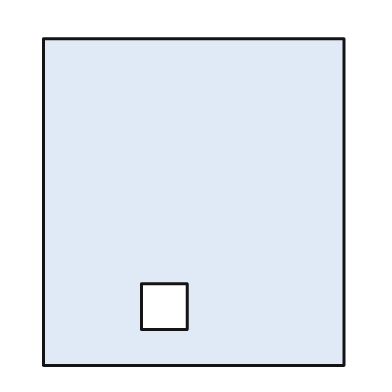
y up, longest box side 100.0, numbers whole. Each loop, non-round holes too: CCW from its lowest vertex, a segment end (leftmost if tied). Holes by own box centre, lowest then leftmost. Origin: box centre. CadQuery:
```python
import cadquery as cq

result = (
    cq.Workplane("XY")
    .moveTo(-46.0, -50.0)
    .lineTo(46.0, -50.0)
    .lineTo(46.0, 50.0)
    .lineTo(-46.0, 50.0)
    .close()
    .moveTo(-16.0, -39.0)
    .lineTo(-2.0, -39.0)
    .lineTo(-2.0, -25.0)
    .lineTo(-16.0, -25.0)
    .close()
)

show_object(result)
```